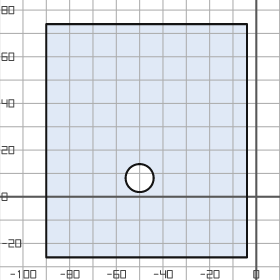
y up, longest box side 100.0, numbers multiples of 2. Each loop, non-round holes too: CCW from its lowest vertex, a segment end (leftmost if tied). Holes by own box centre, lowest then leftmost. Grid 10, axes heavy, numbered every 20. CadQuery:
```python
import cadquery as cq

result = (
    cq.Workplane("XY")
    .moveTo(-90.0, -26.0)
    .lineTo(-4.0, -26.0)
    .lineTo(-4.0, 74.0)
    .lineTo(-90.0, 74.0)
    .close()
    .moveTo(-50.0, 8.0)
    .circle(6.0)
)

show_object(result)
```